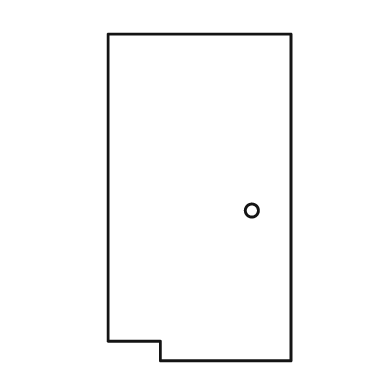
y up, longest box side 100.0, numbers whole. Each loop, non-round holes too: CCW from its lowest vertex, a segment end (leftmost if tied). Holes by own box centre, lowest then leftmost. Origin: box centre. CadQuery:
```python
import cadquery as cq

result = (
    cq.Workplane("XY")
    .moveTo(-12.0, -50.0)
    .lineTo(28.0, -50.0)
    .lineTo(28.0, 50.0)
    .lineTo(-28.0, 50.0)
    .lineTo(-28.0, -44.0)
    .lineTo(-12.0, -44.0)
    .close()
    .moveTo(16.0, -4.0)
    .circle(2.0)
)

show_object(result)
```